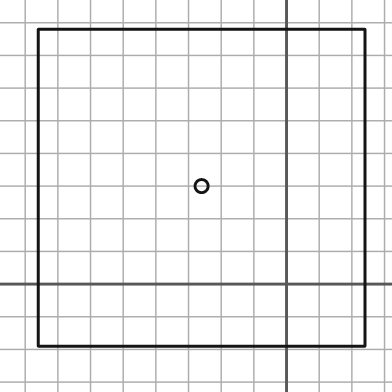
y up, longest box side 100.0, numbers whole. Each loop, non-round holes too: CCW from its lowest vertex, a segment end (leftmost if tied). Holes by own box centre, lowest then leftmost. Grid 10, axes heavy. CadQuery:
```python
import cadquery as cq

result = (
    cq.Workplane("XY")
    .moveTo(-76.0, -19.0)
    .lineTo(24.0, -19.0)
    .lineTo(24.0, 78.0)
    .lineTo(-76.0, 78.0)
    .close()
    .moveTo(-26.0, 30.0)
    .circle(2.0)
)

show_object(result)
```